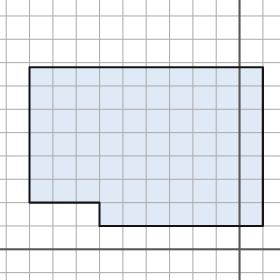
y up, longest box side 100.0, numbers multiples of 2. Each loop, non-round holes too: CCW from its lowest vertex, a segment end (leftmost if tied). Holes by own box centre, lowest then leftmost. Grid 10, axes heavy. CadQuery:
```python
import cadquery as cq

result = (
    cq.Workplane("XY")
    .moveTo(-60.0, 10.0)
    .lineTo(10.0, 10.0)
    .lineTo(10.0, 78.0)
    .lineTo(-90.0, 78.0)
    .lineTo(-90.0, 20.0)
    .lineTo(-60.0, 20.0)
    .close()
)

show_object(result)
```